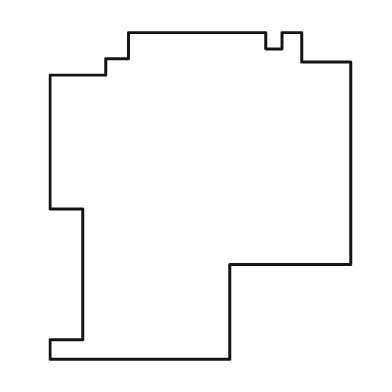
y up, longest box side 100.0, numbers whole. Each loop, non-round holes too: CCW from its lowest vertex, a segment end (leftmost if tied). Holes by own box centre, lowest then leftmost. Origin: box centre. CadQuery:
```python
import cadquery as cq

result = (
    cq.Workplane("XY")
    .moveTo(-46.0, -50.0)
    .lineTo(9.0, -50.0)
    .lineTo(9.0, -21.0)
    .lineTo(46.0, -21.0)
    .lineTo(46.0, 41.0)
    .lineTo(31.0, 41.0)
    .lineTo(31.0, 50.0)
    .lineTo(25.0, 50.0)
    .lineTo(25.0, 45.0)
    .lineTo(20.0, 45.0)
    .lineTo(20.0, 50.0)
    .lineTo(-22.0, 50.0)
    .lineTo(-22.0, 42.0)
    .lineTo(-29.0, 42.0)
    .lineTo(-29.0, 37.0)
    .lineTo(-46.0, 37.0)
    .lineTo(-46.0, -4.0)
    .lineTo(-36.0, -4.0)
    .lineTo(-36.0, -44.0)
    .lineTo(-46.0, -44.0)
    .close()
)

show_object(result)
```